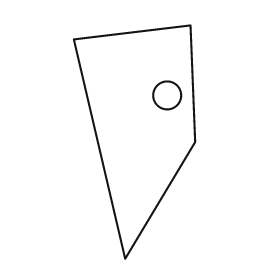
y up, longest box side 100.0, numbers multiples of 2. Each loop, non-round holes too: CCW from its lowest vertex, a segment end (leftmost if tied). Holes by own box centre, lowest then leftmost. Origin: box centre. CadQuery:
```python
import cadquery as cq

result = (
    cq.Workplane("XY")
    .moveTo(-4.0, -50.0)
    .lineTo(26.0, 0.0)
    .lineTo(24.0, 50.0)
    .lineTo(-26.0, 44.0)
    .close()
    .moveTo(14.0, 20.0)
    .circle(6.0)
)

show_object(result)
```